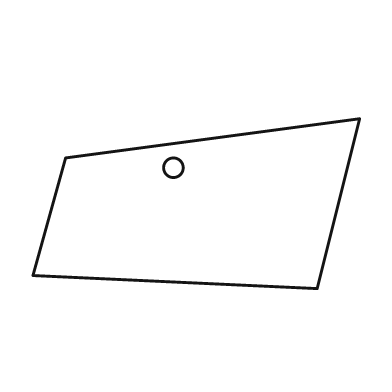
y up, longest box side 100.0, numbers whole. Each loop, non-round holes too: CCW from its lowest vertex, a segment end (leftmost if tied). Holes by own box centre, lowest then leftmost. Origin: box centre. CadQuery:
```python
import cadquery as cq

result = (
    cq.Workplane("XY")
    .moveTo(37.0, -26.0)
    .lineTo(50.0, 26.0)
    .lineTo(-40.0, 14.0)
    .lineTo(-50.0, -22.0)
    .close()
    .moveTo(-7.0, 11.0)
    .circle(3.0)
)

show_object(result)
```